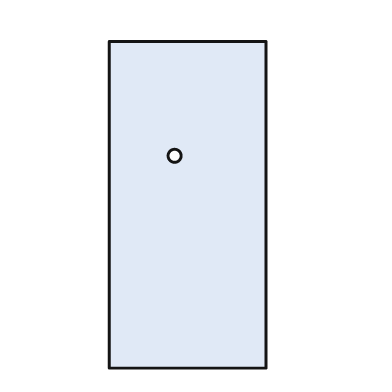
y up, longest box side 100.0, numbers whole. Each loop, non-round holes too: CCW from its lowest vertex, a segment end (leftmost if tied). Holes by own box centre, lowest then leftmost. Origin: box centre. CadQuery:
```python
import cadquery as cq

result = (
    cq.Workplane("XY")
    .moveTo(-24.0, -50.0)
    .lineTo(24.0, -50.0)
    .lineTo(24.0, 50.0)
    .lineTo(-24.0, 50.0)
    .close()
    .moveTo(-4.0, 15.0)
    .circle(2.0)
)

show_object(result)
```